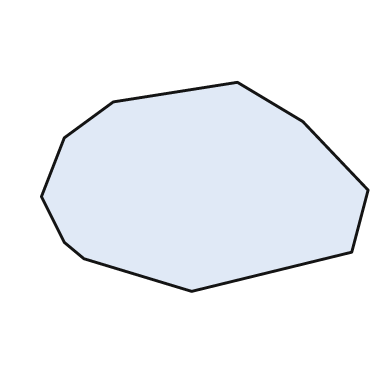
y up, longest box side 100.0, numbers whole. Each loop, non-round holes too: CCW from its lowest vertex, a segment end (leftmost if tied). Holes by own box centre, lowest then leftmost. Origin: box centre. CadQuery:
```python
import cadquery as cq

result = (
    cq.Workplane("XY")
    .moveTo(-4.0, -32.0)
    .lineTo(45.0, -20.0)
    .lineTo(50.0, -1.0)
    .lineTo(30.0, 20.0)
    .lineTo(10.0, 32.0)
    .lineTo(-28.0, 26.0)
    .lineTo(-43.0, 15.0)
    .lineTo(-50.0, -3.0)
    .lineTo(-43.0, -17.0)
    .lineTo(-37.0, -22.0)
    .close()
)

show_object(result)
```